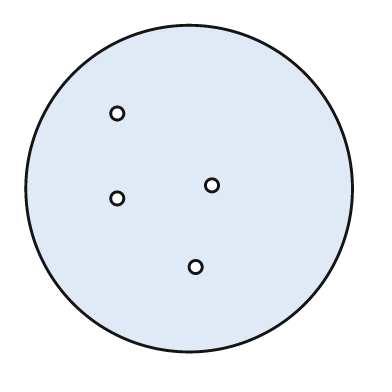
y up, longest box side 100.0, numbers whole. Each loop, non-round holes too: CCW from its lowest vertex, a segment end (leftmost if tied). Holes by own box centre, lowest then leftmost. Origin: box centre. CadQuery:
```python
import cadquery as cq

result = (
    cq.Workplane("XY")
    .moveTo(0.0, 0.0)
    .circle(50.0)
    .moveTo(2.0, -24.0)
    .circle(2.0)
    .moveTo(-22.0, -3.0)
    .circle(2.0)
    .moveTo(7.0, 1.0)
    .circle(2.0)
    .moveTo(-22.0, 23.0)
    .circle(2.0)
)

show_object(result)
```